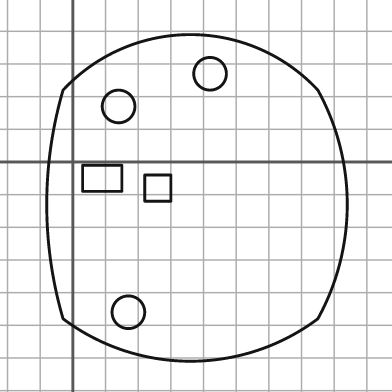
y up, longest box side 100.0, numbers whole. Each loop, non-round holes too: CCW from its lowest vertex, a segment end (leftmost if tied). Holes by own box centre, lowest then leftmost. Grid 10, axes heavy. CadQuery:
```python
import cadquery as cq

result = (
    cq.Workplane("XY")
    .moveTo(-3.0, -48.0)
    .threePointArc((36.0, -61.0), (75.0, -48.0))
    .threePointArc((84.0, -13.0), (75.0, 22.0))
    .threePointArc((36.0, 39.0), (-3.0, 22.0))
    .threePointArc((-8.0, -13.0), (-3.0, -48.0))
    .close()
    .moveTo(17.0, -46.0)
    .circle(5.0)
    .moveTo(22.0, -12.0)
    .lineTo(30.0, -12.0)
    .lineTo(30.0, -4.0)
    .lineTo(22.0, -4.0)
    .close()
    .moveTo(3.0, -9.0)
    .lineTo(15.0, -9.0)
    .lineTo(15.0, -1.0)
    .lineTo(3.0, -1.0)
    .close()
    .moveTo(14.0, 17.0)
    .circle(5.0)
    .moveTo(42.0, 27.0)
    .circle(5.0)
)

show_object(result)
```